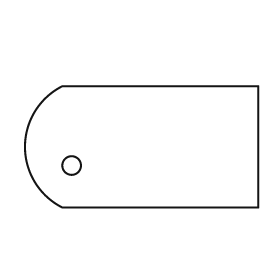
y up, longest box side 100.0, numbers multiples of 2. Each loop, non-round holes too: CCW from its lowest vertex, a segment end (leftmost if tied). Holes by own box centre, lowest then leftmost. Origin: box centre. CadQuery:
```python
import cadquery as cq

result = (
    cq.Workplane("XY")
    .moveTo(-34.0, -26.0)
    .lineTo(50.0, -26.0)
    .lineTo(50.0, 26.0)
    .lineTo(-34.0, 26.0)
    .threePointArc((-50.0, 0.0), (-34.0, -26.0))
    .close()
    .moveTo(-30.0, -8.0)
    .circle(4.0)
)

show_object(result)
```